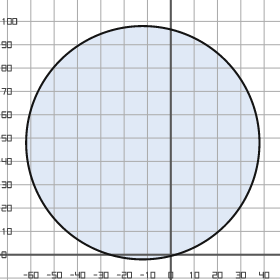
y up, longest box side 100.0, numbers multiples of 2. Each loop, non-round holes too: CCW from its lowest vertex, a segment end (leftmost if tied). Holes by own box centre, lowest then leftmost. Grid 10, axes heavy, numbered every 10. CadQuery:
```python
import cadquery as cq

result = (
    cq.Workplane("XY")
    .moveTo(-12.0, 48.0)
    .circle(50.0)
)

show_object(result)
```